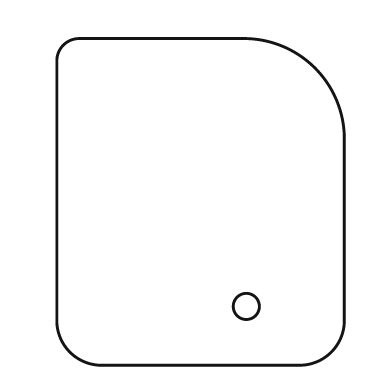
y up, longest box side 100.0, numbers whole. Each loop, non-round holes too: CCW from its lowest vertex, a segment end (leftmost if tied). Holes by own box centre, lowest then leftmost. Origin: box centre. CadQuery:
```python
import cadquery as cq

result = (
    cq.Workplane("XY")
    .moveTo(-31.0, -50.0)
    .lineTo(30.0, -50.0)
    .threePointArc((40.0, -46.0), (44.0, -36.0))
    .lineTo(44.0, 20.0)
    .threePointArc((35.0, 41.0), (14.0, 50.0))
    .lineTo(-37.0, 50.0)
    .threePointArc((-42.0, 48.0), (-44.0, 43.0))
    .lineTo(-44.0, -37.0)
    .threePointArc((-40.0, -46.0), (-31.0, -50.0))
    .close()
    .moveTo(14.0, -32.0)
    .circle(4.0)
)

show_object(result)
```